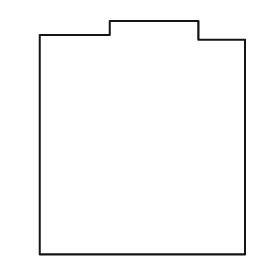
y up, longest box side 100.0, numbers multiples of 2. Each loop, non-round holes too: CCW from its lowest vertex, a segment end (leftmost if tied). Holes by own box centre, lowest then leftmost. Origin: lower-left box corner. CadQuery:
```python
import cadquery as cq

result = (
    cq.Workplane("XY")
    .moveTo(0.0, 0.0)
    .lineTo(88.0, 0.0)
    .lineTo(88.0, 92.0)
    .lineTo(68.0, 92.0)
    .lineTo(68.0, 100.0)
    .lineTo(30.0, 100.0)
    .lineTo(30.0, 94.0)
    .lineTo(0.0, 94.0)
    .close()
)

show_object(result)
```